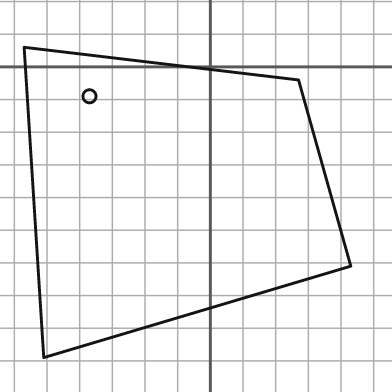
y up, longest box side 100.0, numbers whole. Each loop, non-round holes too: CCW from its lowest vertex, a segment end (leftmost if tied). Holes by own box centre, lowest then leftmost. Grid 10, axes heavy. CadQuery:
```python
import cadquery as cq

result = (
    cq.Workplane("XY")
    .moveTo(-51.0, -89.0)
    .lineTo(43.0, -61.0)
    .lineTo(27.0, -4.0)
    .lineTo(-57.0, 6.0)
    .close()
    .moveTo(-37.0, -9.0)
    .circle(2.0)
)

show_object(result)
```